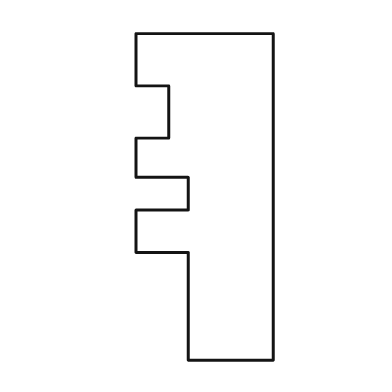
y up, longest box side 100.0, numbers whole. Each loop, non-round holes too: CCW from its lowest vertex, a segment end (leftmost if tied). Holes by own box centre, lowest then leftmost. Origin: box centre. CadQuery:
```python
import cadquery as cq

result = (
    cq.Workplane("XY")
    .moveTo(-5.0, -50.0)
    .lineTo(21.0, -50.0)
    .lineTo(21.0, 50.0)
    .lineTo(-21.0, 50.0)
    .lineTo(-21.0, 34.0)
    .lineTo(-11.0, 34.0)
    .lineTo(-11.0, 18.0)
    .lineTo(-21.0, 18.0)
    .lineTo(-21.0, 6.0)
    .lineTo(-5.0, 6.0)
    .lineTo(-5.0, -4.0)
    .lineTo(-21.0, -4.0)
    .lineTo(-21.0, -17.0)
    .lineTo(-5.0, -17.0)
    .close()
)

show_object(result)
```